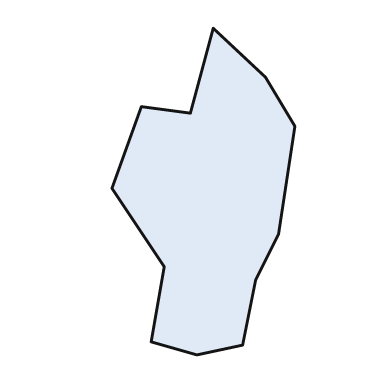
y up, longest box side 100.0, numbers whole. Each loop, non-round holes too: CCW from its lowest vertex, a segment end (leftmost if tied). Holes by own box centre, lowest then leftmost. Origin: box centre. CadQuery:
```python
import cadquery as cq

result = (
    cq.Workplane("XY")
    .moveTo(-2.0, -50.0)
    .lineTo(12.0, -47.0)
    .lineTo(16.0, -27.0)
    .lineTo(23.0, -13.0)
    .lineTo(28.0, 20.0)
    .lineTo(19.0, 35.0)
    .lineTo(3.0, 50.0)
    .lineTo(-4.0, 24.0)
    .lineTo(-19.0, 26.0)
    .lineTo(-28.0, 1.0)
    .lineTo(-12.0, -23.0)
    .lineTo(-16.0, -46.0)
    .close()
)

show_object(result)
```